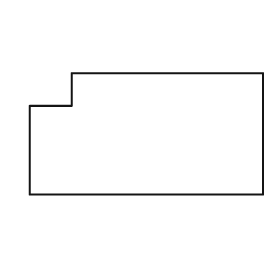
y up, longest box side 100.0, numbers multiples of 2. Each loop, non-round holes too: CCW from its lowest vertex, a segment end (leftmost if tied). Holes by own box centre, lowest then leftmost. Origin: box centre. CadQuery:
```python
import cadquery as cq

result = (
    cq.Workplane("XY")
    .moveTo(-50.0, -26.0)
    .lineTo(50.0, -26.0)
    .lineTo(50.0, 26.0)
    .lineTo(-32.0, 26.0)
    .lineTo(-32.0, 12.0)
    .lineTo(-50.0, 12.0)
    .close()
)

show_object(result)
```